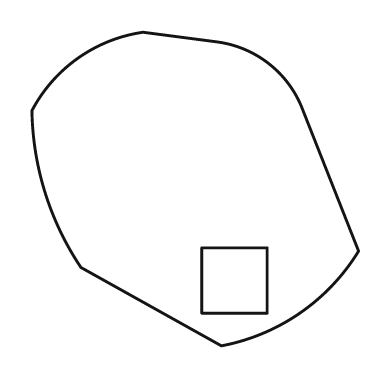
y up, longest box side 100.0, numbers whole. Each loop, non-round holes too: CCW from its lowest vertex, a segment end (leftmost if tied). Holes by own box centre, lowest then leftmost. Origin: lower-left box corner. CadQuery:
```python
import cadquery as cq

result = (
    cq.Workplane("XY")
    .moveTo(58.0, 0.0)
    .threePointArc((82.0, 10.0), (100.0, 29.0))
    .lineTo(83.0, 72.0)
    .threePointArc((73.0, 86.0), (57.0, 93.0))
    .lineTo(34.0, 96.0)
    .threePointArc((14.0, 88.0), (0.0, 72.0))
    .threePointArc((4.0, 47.0), (15.0, 24.0))
    .close()
    .moveTo(52.0, 10.0)
    .lineTo(72.0, 10.0)
    .lineTo(72.0, 30.0)
    .lineTo(52.0, 30.0)
    .close()
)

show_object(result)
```